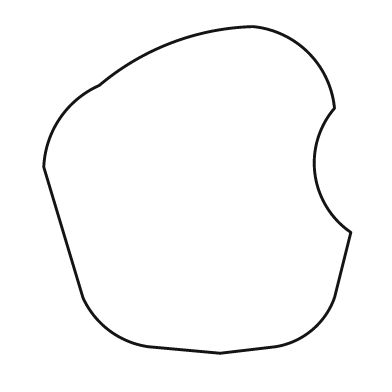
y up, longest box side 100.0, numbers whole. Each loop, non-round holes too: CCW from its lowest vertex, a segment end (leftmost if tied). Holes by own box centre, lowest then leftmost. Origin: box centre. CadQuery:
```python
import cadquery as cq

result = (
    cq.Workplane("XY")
    .moveTo(7.0, -50.0)
    .lineTo(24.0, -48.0)
    .threePointArc((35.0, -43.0), (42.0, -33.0))
    .lineTo(47.0, -13.0)
    .threePointArc((36.0, 5.0), (42.0, 25.0))
    .threePointArc((34.0, 42.0), (17.0, 50.0))
    .threePointArc((-8.0, 45.0), (-30.0, 32.0))
    .threePointArc((-42.0, 22.0), (-47.0, 7.0))
    .lineTo(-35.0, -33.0)
    .threePointArc((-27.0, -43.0), (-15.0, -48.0))
    .close()
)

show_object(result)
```